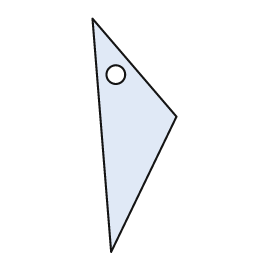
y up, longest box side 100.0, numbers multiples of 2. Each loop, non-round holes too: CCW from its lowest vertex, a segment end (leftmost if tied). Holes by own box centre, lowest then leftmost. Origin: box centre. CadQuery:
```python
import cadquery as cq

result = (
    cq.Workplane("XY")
    .moveTo(-10.0, -50.0)
    .lineTo(18.0, 8.0)
    .lineTo(-18.0, 50.0)
    .close()
    .moveTo(-8.0, 26.0)
    .circle(4.0)
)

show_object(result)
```